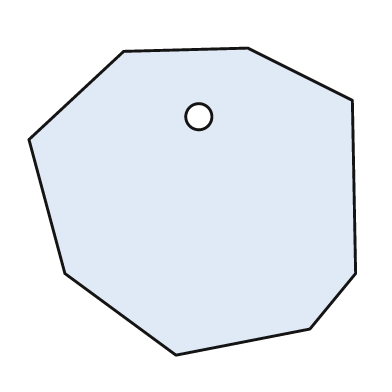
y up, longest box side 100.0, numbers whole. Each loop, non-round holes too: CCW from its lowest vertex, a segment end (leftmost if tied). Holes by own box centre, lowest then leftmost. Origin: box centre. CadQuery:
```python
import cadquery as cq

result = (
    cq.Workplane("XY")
    .moveTo(-5.0, -47.0)
    .lineTo(36.0, -39.0)
    .lineTo(50.0, -22.0)
    .lineTo(49.0, 31.0)
    .lineTo(17.0, 47.0)
    .lineTo(-21.0, 46.0)
    .lineTo(-50.0, 19.0)
    .lineTo(-39.0, -22.0)
    .close()
    .moveTo(2.0, 26.0)
    .circle(4.0)
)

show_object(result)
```